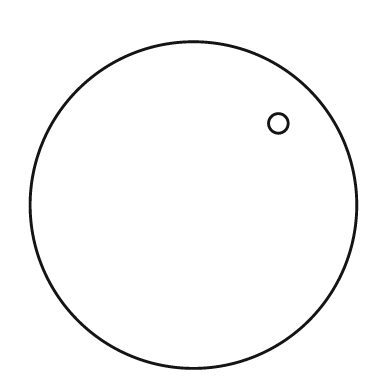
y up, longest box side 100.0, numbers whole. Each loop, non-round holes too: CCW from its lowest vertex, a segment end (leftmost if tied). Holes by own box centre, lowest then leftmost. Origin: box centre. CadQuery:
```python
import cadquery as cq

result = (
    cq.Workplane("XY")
    .moveTo(0.0, 0.0)
    .circle(50.0)
    .moveTo(26.0, 25.0)
    .circle(3.0)
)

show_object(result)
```